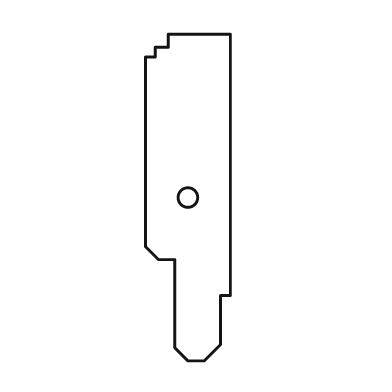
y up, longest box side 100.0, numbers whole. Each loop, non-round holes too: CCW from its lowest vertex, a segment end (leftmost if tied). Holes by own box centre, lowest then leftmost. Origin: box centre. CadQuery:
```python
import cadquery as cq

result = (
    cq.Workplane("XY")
    .moveTo(0.0, -50.0)
    .lineTo(5.0, -50.0)
    .lineTo(10.0, -45.0)
    .lineTo(10.0, -30.0)
    .lineTo(13.0, -30.0)
    .lineTo(13.0, 50.0)
    .lineTo(-6.0, 50.0)
    .lineTo(-6.0, 46.0)
    .lineTo(-10.0, 46.0)
    .lineTo(-10.0, 43.0)
    .lineTo(-13.0, 43.0)
    .lineTo(-13.0, -15.0)
    .lineTo(-9.0, -19.0)
    .lineTo(-4.0, -19.0)
    .lineTo(-4.0, -46.0)
    .close()
    .moveTo(0.0, 0.0)
    .circle(3.0)
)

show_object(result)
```